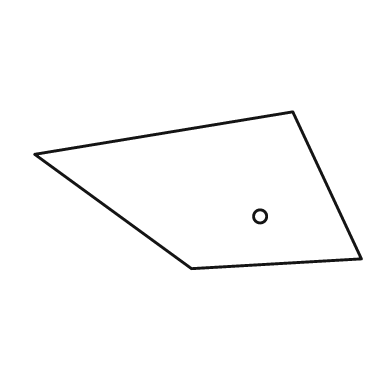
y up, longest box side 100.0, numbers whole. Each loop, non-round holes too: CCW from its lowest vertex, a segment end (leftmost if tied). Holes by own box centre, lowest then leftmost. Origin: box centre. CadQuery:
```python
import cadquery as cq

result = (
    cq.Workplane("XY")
    .moveTo(-2.0, -24.0)
    .lineTo(50.0, -21.0)
    .lineTo(29.0, 24.0)
    .lineTo(-50.0, 11.0)
    .close()
    .moveTo(19.0, -8.0)
    .circle(2.0)
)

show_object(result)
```